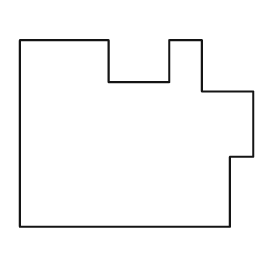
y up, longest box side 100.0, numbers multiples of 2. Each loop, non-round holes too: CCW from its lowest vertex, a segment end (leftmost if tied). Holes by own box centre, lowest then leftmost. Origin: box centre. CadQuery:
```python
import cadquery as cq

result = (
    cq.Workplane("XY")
    .moveTo(-50.0, -40.0)
    .lineTo(40.0, -40.0)
    .lineTo(40.0, -10.0)
    .lineTo(50.0, -10.0)
    .lineTo(50.0, 18.0)
    .lineTo(28.0, 18.0)
    .lineTo(28.0, 40.0)
    .lineTo(14.0, 40.0)
    .lineTo(14.0, 22.0)
    .lineTo(-12.0, 22.0)
    .lineTo(-12.0, 40.0)
    .lineTo(-50.0, 40.0)
    .close()
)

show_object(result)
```